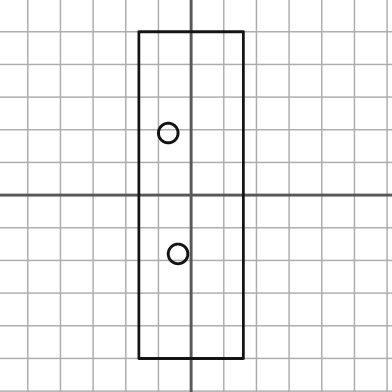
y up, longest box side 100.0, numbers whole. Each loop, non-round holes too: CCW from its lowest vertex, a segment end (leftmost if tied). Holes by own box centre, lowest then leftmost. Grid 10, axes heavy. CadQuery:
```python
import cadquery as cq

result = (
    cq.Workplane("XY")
    .moveTo(-16.0, -50.0)
    .lineTo(16.0, -50.0)
    .lineTo(16.0, 50.0)
    .lineTo(-16.0, 50.0)
    .close()
    .moveTo(-4.0, -18.0)
    .circle(3.0)
    .moveTo(-7.0, 19.0)
    .circle(3.0)
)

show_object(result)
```